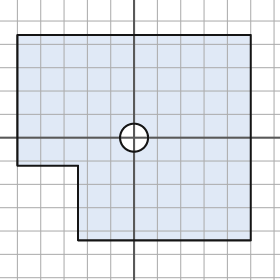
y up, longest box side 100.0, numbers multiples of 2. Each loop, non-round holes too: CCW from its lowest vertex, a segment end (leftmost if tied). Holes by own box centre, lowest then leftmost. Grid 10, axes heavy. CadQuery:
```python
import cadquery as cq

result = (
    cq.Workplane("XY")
    .moveTo(-24.0, -44.0)
    .lineTo(50.0, -44.0)
    .lineTo(50.0, 44.0)
    .lineTo(-50.0, 44.0)
    .lineTo(-50.0, -12.0)
    .lineTo(-24.0, -12.0)
    .close()
    .moveTo(0.0, 0.0)
    .circle(6.0)
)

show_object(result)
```